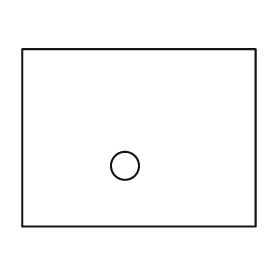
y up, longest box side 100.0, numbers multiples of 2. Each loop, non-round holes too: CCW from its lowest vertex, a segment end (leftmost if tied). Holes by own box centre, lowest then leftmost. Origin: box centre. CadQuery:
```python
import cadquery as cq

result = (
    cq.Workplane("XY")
    .moveTo(-50.0, -38.0)
    .lineTo(50.0, -38.0)
    .lineTo(50.0, 38.0)
    .lineTo(-50.0, 38.0)
    .close()
    .moveTo(-6.0, -12.0)
    .circle(6.0)
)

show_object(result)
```